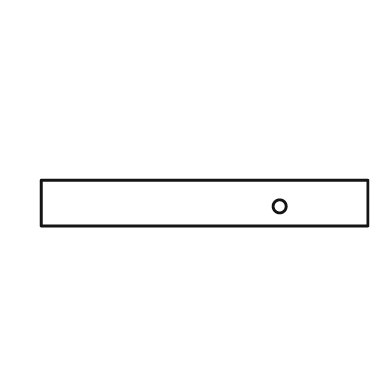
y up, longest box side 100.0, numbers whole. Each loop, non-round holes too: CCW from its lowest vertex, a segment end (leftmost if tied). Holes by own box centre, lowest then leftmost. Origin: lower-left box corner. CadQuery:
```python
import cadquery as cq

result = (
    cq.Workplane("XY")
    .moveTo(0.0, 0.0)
    .lineTo(100.0, 0.0)
    .lineTo(100.0, 14.0)
    .lineTo(0.0, 14.0)
    .close()
    .moveTo(73.0, 6.0)
    .circle(2.0)
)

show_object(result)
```